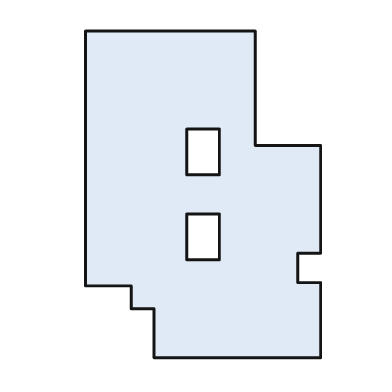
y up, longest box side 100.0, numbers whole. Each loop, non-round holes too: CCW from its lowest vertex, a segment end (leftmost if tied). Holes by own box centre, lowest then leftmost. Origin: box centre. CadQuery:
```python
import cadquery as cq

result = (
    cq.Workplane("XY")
    .moveTo(-15.0, -50.0)
    .lineTo(36.0, -50.0)
    .lineTo(36.0, -27.0)
    .lineTo(29.0, -27.0)
    .lineTo(29.0, -18.0)
    .lineTo(36.0, -18.0)
    .lineTo(36.0, 15.0)
    .lineTo(16.0, 15.0)
    .lineTo(16.0, 50.0)
    .lineTo(-36.0, 50.0)
    .lineTo(-36.0, -28.0)
    .lineTo(-22.0, -28.0)
    .lineTo(-22.0, -35.0)
    .lineTo(-15.0, -35.0)
    .close()
    .moveTo(-5.0, -20.0)
    .lineTo(5.0, -20.0)
    .lineTo(5.0, -6.0)
    .lineTo(-5.0, -6.0)
    .close()
    .moveTo(-5.0, 6.0)
    .lineTo(5.0, 6.0)
    .lineTo(5.0, 20.0)
    .lineTo(-5.0, 20.0)
    .close()
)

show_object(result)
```